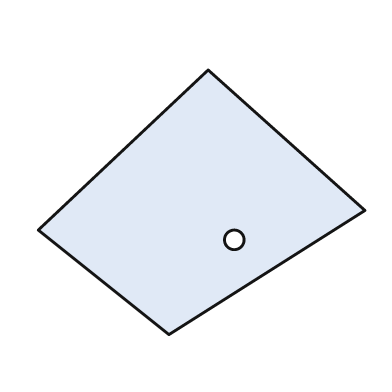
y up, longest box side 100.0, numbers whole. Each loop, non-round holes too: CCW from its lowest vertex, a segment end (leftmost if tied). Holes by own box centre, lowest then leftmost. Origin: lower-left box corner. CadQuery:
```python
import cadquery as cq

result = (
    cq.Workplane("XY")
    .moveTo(40.0, 0.0)
    .lineTo(100.0, 38.0)
    .lineTo(52.0, 81.0)
    .lineTo(0.0, 32.0)
    .close()
    .moveTo(60.0, 29.0)
    .circle(3.0)
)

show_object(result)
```